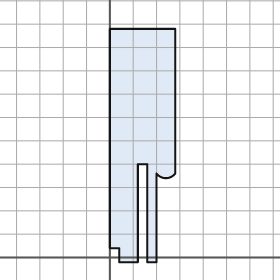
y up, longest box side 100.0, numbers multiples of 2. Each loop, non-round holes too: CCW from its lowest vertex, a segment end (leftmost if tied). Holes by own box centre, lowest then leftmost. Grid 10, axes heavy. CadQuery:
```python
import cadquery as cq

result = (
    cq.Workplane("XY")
    .moveTo(4.0, -2.0)
    .lineTo(12.0, -2.0)
    .lineTo(12.0, 40.0)
    .lineTo(16.0, 40.0)
    .lineTo(16.0, -2.0)
    .lineTo(20.0, -2.0)
    .lineTo(20.0, 36.0)
    .threePointArc((24.0, 34.0), (28.0, 36.0))
    .lineTo(28.0, 98.0)
    .lineTo(0.0, 98.0)
    .lineTo(0.0, 4.0)
    .lineTo(4.0, 4.0)
    .close()
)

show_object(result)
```